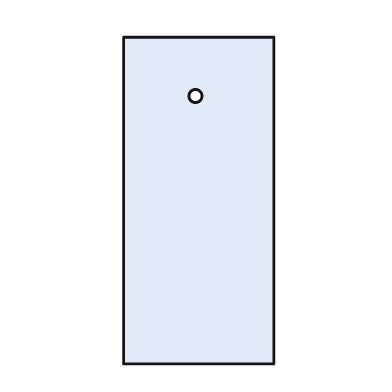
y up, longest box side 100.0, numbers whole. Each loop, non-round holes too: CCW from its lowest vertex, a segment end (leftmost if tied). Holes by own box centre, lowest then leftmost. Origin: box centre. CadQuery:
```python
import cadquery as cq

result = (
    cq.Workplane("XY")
    .moveTo(-23.0, -50.0)
    .lineTo(23.0, -50.0)
    .lineTo(23.0, 50.0)
    .lineTo(-23.0, 50.0)
    .close()
    .moveTo(-1.0, 32.0)
    .circle(2.0)
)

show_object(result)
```